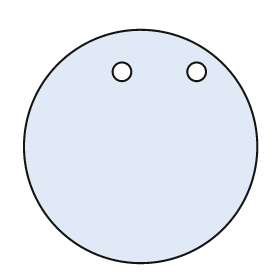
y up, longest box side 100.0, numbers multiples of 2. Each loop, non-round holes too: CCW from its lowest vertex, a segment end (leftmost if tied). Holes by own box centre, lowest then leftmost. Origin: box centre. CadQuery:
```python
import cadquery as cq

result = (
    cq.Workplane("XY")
    .moveTo(0.0, 0.0)
    .circle(50.0)
    .moveTo(-8.0, 32.0)
    .circle(4.0)
    .moveTo(24.0, 32.0)
    .circle(4.0)
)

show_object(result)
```